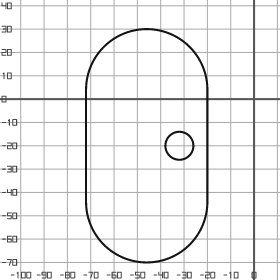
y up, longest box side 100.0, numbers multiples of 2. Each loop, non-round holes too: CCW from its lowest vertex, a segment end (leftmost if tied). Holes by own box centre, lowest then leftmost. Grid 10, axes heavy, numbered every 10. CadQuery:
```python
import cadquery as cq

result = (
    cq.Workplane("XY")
    .moveTo(-72.0, -44.0)
    .threePointArc((-46.0, -70.0), (-20.0, -44.0))
    .lineTo(-20.0, 4.0)
    .threePointArc((-46.0, 30.0), (-72.0, 4.0))
    .close()
    .moveTo(-32.0, -20.0)
    .circle(6.0)
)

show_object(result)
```